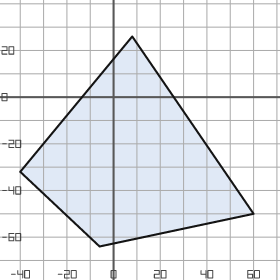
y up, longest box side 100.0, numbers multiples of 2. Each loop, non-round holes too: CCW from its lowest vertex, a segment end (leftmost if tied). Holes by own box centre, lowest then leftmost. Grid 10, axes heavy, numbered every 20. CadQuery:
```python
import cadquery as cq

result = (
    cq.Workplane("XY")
    .moveTo(-6.0, -64.0)
    .lineTo(60.0, -50.0)
    .lineTo(8.0, 26.0)
    .lineTo(-40.0, -32.0)
    .close()
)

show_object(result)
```